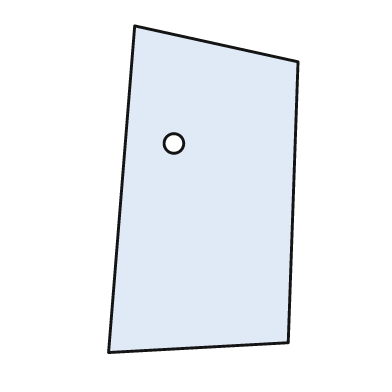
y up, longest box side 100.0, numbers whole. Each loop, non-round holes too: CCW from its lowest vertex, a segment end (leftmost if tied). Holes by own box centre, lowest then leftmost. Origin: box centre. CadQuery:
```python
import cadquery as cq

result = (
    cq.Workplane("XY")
    .moveTo(-29.0, -50.0)
    .lineTo(26.0, -47.0)
    .lineTo(29.0, 39.0)
    .lineTo(-21.0, 50.0)
    .close()
    .moveTo(-9.0, 14.0)
    .circle(3.0)
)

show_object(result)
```